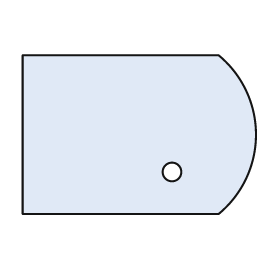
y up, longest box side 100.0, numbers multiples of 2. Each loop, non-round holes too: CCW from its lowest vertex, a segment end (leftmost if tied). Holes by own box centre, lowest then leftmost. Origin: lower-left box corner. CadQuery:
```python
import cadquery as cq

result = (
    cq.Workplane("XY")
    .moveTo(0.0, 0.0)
    .lineTo(84.0, 0.0)
    .threePointArc((100.0, 34.0), (84.0, 68.0))
    .lineTo(0.0, 68.0)
    .close()
    .moveTo(64.0, 18.0)
    .circle(4.0)
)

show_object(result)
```